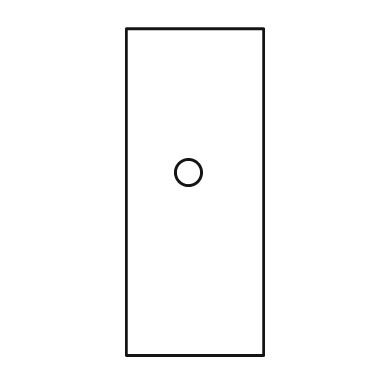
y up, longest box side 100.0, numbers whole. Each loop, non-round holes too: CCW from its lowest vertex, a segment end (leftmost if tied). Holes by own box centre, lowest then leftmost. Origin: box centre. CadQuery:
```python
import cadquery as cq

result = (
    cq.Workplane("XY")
    .moveTo(-21.0, -50.0)
    .lineTo(21.0, -50.0)
    .lineTo(21.0, 50.0)
    .lineTo(-21.0, 50.0)
    .close()
    .moveTo(-2.0, 6.0)
    .circle(4.0)
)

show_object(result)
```